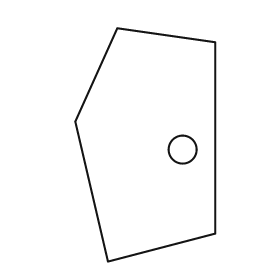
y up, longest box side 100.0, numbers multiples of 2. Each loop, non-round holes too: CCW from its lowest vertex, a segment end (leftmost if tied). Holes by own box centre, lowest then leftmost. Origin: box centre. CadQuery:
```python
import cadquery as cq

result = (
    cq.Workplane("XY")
    .moveTo(-16.0, -50.0)
    .lineTo(30.0, -38.0)
    .lineTo(30.0, 44.0)
    .lineTo(-12.0, 50.0)
    .lineTo(-30.0, 10.0)
    .close()
    .moveTo(16.0, -2.0)
    .circle(6.0)
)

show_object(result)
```